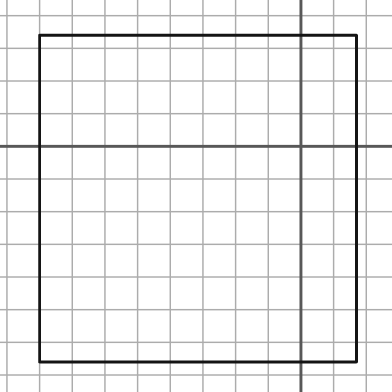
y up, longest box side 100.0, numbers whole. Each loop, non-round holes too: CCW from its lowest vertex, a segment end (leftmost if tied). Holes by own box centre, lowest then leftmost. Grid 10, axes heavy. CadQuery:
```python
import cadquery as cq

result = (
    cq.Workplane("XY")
    .moveTo(-80.0, -66.0)
    .lineTo(17.0, -66.0)
    .lineTo(17.0, 34.0)
    .lineTo(-80.0, 34.0)
    .close()
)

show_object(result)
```